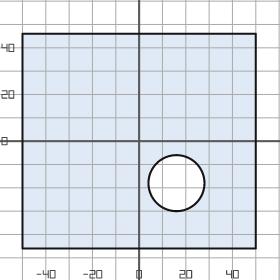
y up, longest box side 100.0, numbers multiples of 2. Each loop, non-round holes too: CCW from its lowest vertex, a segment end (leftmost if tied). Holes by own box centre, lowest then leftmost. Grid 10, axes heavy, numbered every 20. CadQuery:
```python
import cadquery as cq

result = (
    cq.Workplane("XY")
    .moveTo(-50.0, -46.0)
    .lineTo(50.0, -46.0)
    .lineTo(50.0, 46.0)
    .lineTo(-50.0, 46.0)
    .close()
    .moveTo(16.0, -18.0)
    .circle(12.0)
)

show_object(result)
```